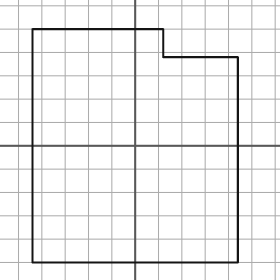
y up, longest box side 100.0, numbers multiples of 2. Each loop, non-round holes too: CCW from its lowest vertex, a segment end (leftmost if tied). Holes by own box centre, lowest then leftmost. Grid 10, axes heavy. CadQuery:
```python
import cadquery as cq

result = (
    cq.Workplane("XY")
    .moveTo(-44.0, -50.0)
    .lineTo(44.0, -50.0)
    .lineTo(44.0, 38.0)
    .lineTo(12.0, 38.0)
    .lineTo(12.0, 50.0)
    .lineTo(-44.0, 50.0)
    .close()
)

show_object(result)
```